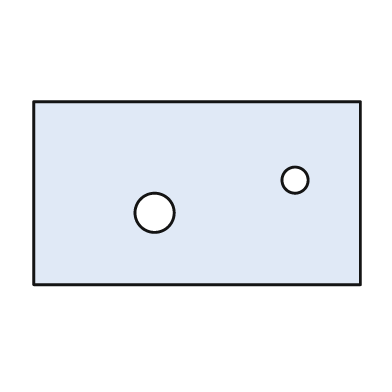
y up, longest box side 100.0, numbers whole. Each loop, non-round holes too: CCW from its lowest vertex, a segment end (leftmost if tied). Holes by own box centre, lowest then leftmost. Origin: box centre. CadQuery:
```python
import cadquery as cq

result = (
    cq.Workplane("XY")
    .moveTo(-50.0, -28.0)
    .lineTo(50.0, -28.0)
    .lineTo(50.0, 28.0)
    .lineTo(-50.0, 28.0)
    .close()
    .moveTo(-13.0, -6.0)
    .circle(6.0)
    .moveTo(30.0, 4.0)
    .circle(4.0)
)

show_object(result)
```